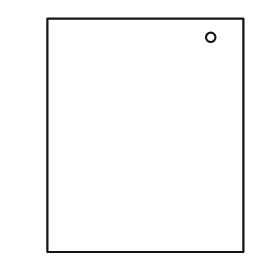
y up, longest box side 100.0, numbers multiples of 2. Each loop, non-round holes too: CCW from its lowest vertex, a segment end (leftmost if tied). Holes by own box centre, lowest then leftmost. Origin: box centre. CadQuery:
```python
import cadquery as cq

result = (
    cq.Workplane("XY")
    .moveTo(-42.0, -50.0)
    .lineTo(42.0, -50.0)
    .lineTo(42.0, 50.0)
    .lineTo(-42.0, 50.0)
    .close()
    .moveTo(28.0, 42.0)
    .circle(2.0)
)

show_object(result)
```